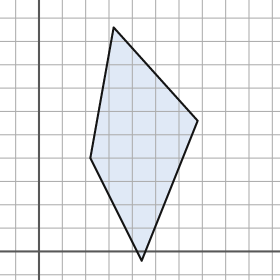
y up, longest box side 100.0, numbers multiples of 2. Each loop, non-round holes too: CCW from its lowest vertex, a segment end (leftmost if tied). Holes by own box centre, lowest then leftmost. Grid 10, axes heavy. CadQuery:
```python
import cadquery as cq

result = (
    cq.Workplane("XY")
    .moveTo(44.0, -4.0)
    .lineTo(68.0, 56.0)
    .lineTo(32.0, 96.0)
    .lineTo(22.0, 40.0)
    .close()
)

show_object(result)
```